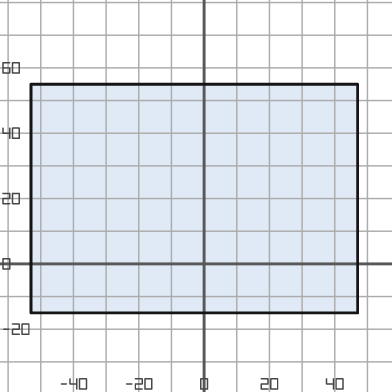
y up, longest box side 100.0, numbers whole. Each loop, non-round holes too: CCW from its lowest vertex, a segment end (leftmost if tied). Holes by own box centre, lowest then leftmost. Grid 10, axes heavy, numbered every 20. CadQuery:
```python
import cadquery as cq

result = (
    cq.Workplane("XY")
    .moveTo(-53.0, -15.0)
    .lineTo(47.0, -15.0)
    .lineTo(47.0, 55.0)
    .lineTo(-53.0, 55.0)
    .close()
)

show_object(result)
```